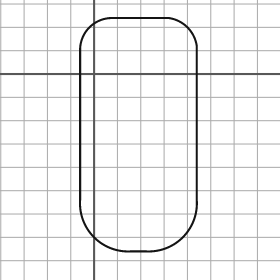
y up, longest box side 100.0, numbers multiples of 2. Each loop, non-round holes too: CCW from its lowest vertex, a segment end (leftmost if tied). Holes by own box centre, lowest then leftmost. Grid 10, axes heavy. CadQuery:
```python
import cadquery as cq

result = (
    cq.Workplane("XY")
    .moveTo(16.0, -76.0)
    .lineTo(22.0, -76.0)
    .threePointArc((38.0, -70.0), (44.0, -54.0))
    .lineTo(44.0, 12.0)
    .threePointArc((40.0, 20.0), (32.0, 24.0))
    .lineTo(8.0, 24.0)
    .threePointArc((-2.0, 20.0), (-6.0, 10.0))
    .lineTo(-6.0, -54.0)
    .threePointArc((0.0, -70.0), (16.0, -76.0))
    .close()
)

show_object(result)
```